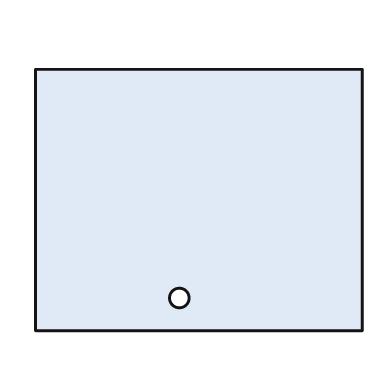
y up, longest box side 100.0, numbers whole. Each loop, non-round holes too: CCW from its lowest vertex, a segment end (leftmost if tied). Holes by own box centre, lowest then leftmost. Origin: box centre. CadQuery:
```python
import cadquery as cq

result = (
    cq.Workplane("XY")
    .moveTo(-50.0, -40.0)
    .lineTo(50.0, -40.0)
    .lineTo(50.0, 40.0)
    .lineTo(-50.0, 40.0)
    .close()
    .moveTo(-6.0, -30.0)
    .circle(3.0)
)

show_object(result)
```